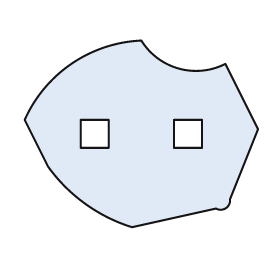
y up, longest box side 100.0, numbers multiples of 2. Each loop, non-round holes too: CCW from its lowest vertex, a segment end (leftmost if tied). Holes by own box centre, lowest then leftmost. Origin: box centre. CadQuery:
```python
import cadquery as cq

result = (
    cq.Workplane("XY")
    .moveTo(-4.0, -40.0)
    .lineTo(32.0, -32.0)
    .threePointArc((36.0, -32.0), (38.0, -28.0))
    .lineTo(50.0, 2.0)
    .lineTo(36.0, 30.0)
    .threePointArc((16.0, 28.0), (0.0, 40.0))
    .threePointArc((-30.0, 30.0), (-50.0, 6.0))
    .lineTo(-40.0, -14.0)
    .threePointArc((-24.0, -30.0), (-4.0, -40.0))
    .close()
    .moveTo(-26.0, -6.0)
    .lineTo(-14.0, -6.0)
    .lineTo(-14.0, 6.0)
    .lineTo(-26.0, 6.0)
    .close()
    .moveTo(14.0, -6.0)
    .lineTo(26.0, -6.0)
    .lineTo(26.0, 6.0)
    .lineTo(14.0, 6.0)
    .close()
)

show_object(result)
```